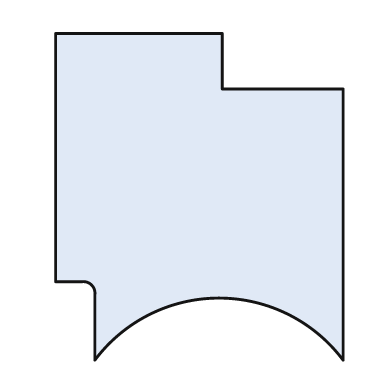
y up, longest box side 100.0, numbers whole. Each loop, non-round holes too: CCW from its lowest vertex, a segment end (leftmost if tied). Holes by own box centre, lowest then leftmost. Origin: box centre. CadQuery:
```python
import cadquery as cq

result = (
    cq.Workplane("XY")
    .moveTo(-32.0, -50.0)
    .threePointArc((6.0, -31.0), (44.0, -50.0))
    .lineTo(44.0, 33.0)
    .lineTo(7.0, 33.0)
    .lineTo(7.0, 50.0)
    .lineTo(-44.0, 50.0)
    .lineTo(-44.0, -26.0)
    .lineTo(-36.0, -26.0)
    .threePointArc((-33.0, -27.0), (-32.0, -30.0))
    .close()
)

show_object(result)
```